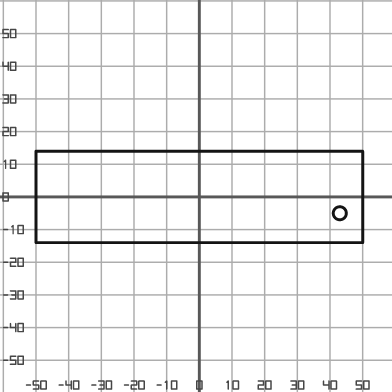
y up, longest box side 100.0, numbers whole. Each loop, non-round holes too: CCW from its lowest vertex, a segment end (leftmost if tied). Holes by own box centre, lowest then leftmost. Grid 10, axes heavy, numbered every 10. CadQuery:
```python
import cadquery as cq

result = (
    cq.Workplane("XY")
    .moveTo(-50.0, -14.0)
    .lineTo(50.0, -14.0)
    .lineTo(50.0, 14.0)
    .lineTo(-50.0, 14.0)
    .close()
    .moveTo(43.0, -5.0)
    .circle(2.0)
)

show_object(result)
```